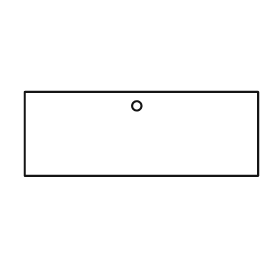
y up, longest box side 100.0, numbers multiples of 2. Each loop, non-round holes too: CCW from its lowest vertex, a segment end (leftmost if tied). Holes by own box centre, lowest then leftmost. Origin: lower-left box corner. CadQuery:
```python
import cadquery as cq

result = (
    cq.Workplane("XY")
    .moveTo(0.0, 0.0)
    .lineTo(100.0, 0.0)
    .lineTo(100.0, 36.0)
    .lineTo(0.0, 36.0)
    .close()
    .moveTo(48.0, 30.0)
    .circle(2.0)
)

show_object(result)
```